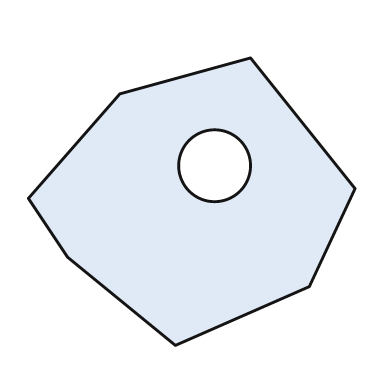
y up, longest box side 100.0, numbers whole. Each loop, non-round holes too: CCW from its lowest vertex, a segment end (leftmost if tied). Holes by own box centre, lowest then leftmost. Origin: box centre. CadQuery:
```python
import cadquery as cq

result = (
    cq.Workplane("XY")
    .moveTo(-5.0, -44.0)
    .lineTo(36.0, -26.0)
    .lineTo(50.0, 4.0)
    .lineTo(18.0, 44.0)
    .lineTo(-22.0, 33.0)
    .lineTo(-50.0, 1.0)
    .lineTo(-38.0, -17.0)
    .close()
    .moveTo(7.0, 11.0)
    .circle(11.0)
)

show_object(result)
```